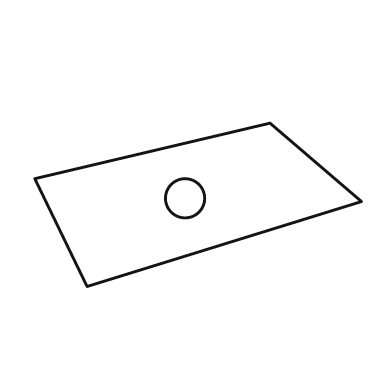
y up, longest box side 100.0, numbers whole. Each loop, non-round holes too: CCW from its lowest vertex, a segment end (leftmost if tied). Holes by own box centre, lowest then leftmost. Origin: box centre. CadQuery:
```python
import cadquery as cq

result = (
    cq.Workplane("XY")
    .moveTo(-34.0, -25.0)
    .lineTo(50.0, 1.0)
    .lineTo(22.0, 25.0)
    .lineTo(-50.0, 8.0)
    .close()
    .moveTo(-4.0, 2.0)
    .circle(6.0)
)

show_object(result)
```